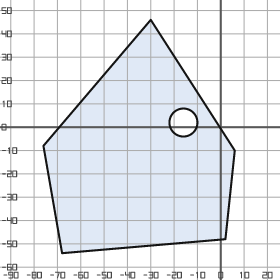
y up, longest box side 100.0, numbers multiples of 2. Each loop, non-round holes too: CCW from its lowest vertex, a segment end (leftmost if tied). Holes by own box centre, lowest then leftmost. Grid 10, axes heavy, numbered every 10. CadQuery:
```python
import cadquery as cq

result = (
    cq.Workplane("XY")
    .moveTo(-68.0, -54.0)
    .lineTo(2.0, -48.0)
    .lineTo(6.0, -10.0)
    .lineTo(-30.0, 46.0)
    .lineTo(-76.0, -8.0)
    .close()
    .moveTo(-16.0, 2.0)
    .circle(6.0)
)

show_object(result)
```